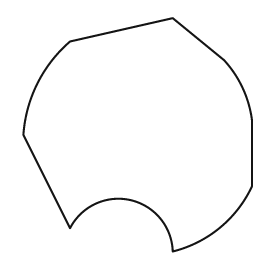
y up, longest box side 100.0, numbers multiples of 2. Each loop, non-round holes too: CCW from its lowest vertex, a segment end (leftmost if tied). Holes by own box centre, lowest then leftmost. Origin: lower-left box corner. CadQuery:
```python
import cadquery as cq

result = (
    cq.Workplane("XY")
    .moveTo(64.0, 0.0)
    .threePointArc((84.0, 10.0), (98.0, 28.0))
    .lineTo(98.0, 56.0)
    .threePointArc((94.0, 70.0), (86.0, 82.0))
    .lineTo(64.0, 100.0)
    .lineTo(20.0, 90.0)
    .threePointArc((6.0, 72.0), (0.0, 50.0))
    .lineTo(20.0, 10.0)
    .threePointArc((46.0, 22.0), (64.0, 0.0))
    .close()
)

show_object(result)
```